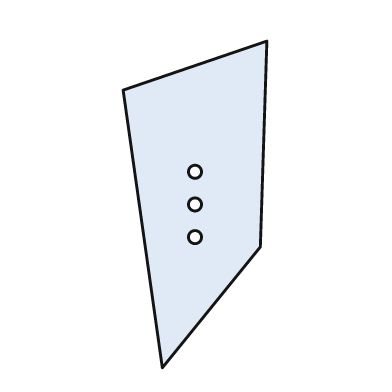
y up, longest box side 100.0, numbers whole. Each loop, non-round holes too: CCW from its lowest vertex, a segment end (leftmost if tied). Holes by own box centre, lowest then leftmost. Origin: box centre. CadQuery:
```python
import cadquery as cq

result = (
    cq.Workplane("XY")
    .moveTo(-10.0, -50.0)
    .lineTo(20.0, -13.0)
    .lineTo(22.0, 50.0)
    .lineTo(-22.0, 35.0)
    .close()
    .moveTo(0.0, -10.0)
    .circle(2.0)
    .moveTo(0.0, 0.0)
    .circle(2.0)
    .moveTo(0.0, 10.0)
    .circle(2.0)
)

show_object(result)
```